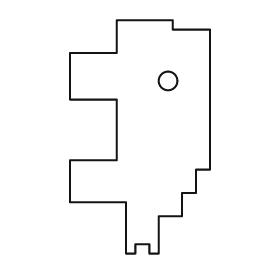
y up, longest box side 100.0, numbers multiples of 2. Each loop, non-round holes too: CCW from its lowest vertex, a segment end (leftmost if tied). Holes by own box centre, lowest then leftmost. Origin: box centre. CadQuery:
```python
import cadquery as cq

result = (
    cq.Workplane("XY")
    .moveTo(-6.0, -50.0)
    .lineTo(-2.0, -50.0)
    .lineTo(-2.0, -46.0)
    .lineTo(4.0, -46.0)
    .lineTo(4.0, -50.0)
    .lineTo(8.0, -50.0)
    .lineTo(8.0, -34.0)
    .lineTo(18.0, -34.0)
    .lineTo(18.0, -24.0)
    .lineTo(24.0, -24.0)
    .lineTo(24.0, -14.0)
    .lineTo(30.0, -14.0)
    .lineTo(30.0, 46.0)
    .lineTo(14.0, 46.0)
    .lineTo(14.0, 50.0)
    .lineTo(-10.0, 50.0)
    .lineTo(-10.0, 36.0)
    .lineTo(-30.0, 36.0)
    .lineTo(-30.0, 16.0)
    .lineTo(-10.0, 16.0)
    .lineTo(-10.0, -10.0)
    .lineTo(-30.0, -10.0)
    .lineTo(-30.0, -28.0)
    .lineTo(-6.0, -28.0)
    .close()
    .moveTo(12.0, 24.0)
    .circle(4.0)
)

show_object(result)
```